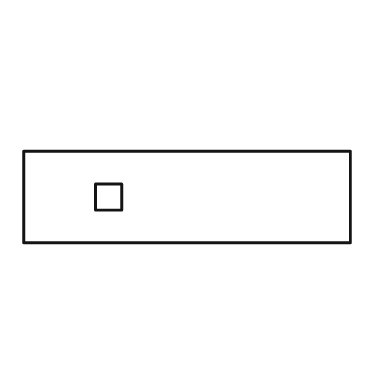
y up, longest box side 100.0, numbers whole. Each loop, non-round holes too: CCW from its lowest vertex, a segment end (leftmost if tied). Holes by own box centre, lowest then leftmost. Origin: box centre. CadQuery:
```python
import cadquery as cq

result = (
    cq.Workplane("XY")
    .moveTo(-50.0, -14.0)
    .lineTo(50.0, -14.0)
    .lineTo(50.0, 14.0)
    .lineTo(-50.0, 14.0)
    .close()
    .moveTo(-28.0, -4.0)
    .lineTo(-20.0, -4.0)
    .lineTo(-20.0, 4.0)
    .lineTo(-28.0, 4.0)
    .close()
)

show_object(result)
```